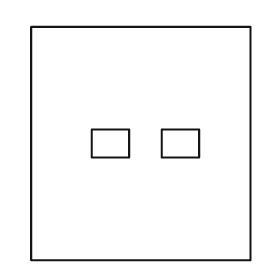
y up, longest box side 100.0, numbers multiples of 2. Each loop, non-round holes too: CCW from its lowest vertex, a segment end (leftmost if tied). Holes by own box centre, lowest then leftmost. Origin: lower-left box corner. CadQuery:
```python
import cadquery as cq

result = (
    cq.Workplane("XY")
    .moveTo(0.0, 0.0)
    .lineTo(94.0, 0.0)
    .lineTo(94.0, 100.0)
    .lineTo(0.0, 100.0)
    .close()
    .moveTo(26.0, 44.0)
    .lineTo(42.0, 44.0)
    .lineTo(42.0, 56.0)
    .lineTo(26.0, 56.0)
    .close()
    .moveTo(56.0, 44.0)
    .lineTo(72.0, 44.0)
    .lineTo(72.0, 56.0)
    .lineTo(56.0, 56.0)
    .close()
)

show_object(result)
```